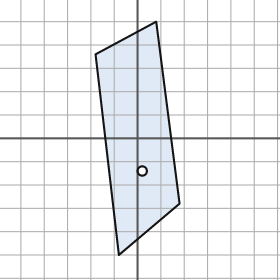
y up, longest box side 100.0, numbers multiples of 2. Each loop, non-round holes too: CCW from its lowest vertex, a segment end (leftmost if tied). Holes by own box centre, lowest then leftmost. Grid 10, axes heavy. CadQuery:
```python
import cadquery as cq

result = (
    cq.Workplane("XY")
    .moveTo(-8.0, -50.0)
    .lineTo(18.0, -28.0)
    .lineTo(8.0, 50.0)
    .lineTo(-18.0, 36.0)
    .close()
    .moveTo(2.0, -14.0)
    .circle(2.0)
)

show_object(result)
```